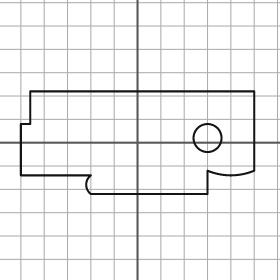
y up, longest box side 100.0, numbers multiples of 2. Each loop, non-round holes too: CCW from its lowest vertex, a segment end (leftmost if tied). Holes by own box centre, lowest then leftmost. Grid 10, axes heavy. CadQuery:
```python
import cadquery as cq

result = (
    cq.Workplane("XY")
    .moveTo(-20.0, -22.0)
    .lineTo(30.0, -22.0)
    .lineTo(30.0, -12.0)
    .threePointArc((40.0, -14.0), (50.0, -12.0))
    .lineTo(50.0, 22.0)
    .lineTo(-46.0, 22.0)
    .lineTo(-46.0, 8.0)
    .lineTo(-50.0, 8.0)
    .lineTo(-50.0, -14.0)
    .lineTo(-20.0, -14.0)
    .threePointArc((-22.0, -18.0), (-20.0, -22.0))
    .close()
    .moveTo(30.0, 2.0)
    .circle(6.0)
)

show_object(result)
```